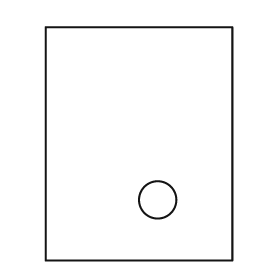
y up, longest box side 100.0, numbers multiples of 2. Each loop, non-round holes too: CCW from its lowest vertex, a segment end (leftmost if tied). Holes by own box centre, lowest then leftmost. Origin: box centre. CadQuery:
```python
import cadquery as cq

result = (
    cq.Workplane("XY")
    .moveTo(-40.0, -50.0)
    .lineTo(40.0, -50.0)
    .lineTo(40.0, 50.0)
    .lineTo(-40.0, 50.0)
    .close()
    .moveTo(8.0, -24.0)
    .circle(8.0)
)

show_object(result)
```